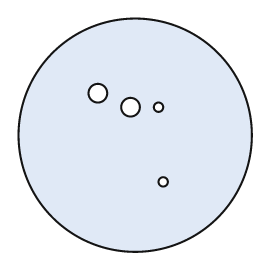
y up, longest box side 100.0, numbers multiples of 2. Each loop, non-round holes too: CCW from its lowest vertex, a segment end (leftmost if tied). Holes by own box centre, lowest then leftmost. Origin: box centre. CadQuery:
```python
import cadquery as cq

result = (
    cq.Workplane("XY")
    .moveTo(0.0, 0.0)
    .circle(50.0)
    .moveTo(12.0, -20.0)
    .circle(2.0)
    .moveTo(-2.0, 12.0)
    .circle(4.0)
    .moveTo(10.0, 12.0)
    .circle(2.0)
    .moveTo(-16.0, 18.0)
    .circle(4.0)
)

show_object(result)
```